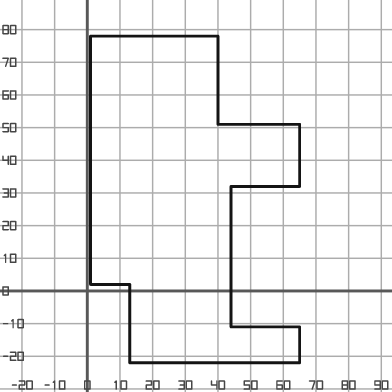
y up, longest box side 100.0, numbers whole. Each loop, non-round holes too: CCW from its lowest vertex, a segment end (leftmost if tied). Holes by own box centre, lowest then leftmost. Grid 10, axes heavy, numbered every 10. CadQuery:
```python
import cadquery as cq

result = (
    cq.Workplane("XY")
    .moveTo(13.0, -22.0)
    .lineTo(65.0, -22.0)
    .lineTo(65.0, -11.0)
    .lineTo(44.0, -11.0)
    .lineTo(44.0, 32.0)
    .lineTo(65.0, 32.0)
    .lineTo(65.0, 51.0)
    .lineTo(40.0, 51.0)
    .lineTo(40.0, 78.0)
    .lineTo(1.0, 78.0)
    .lineTo(1.0, 2.0)
    .lineTo(13.0, 2.0)
    .close()
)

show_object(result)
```